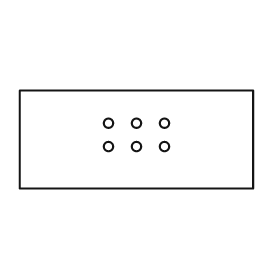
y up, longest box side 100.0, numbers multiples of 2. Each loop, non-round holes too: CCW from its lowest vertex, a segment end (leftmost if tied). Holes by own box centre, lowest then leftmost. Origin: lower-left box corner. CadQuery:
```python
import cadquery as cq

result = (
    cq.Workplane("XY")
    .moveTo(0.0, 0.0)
    .lineTo(100.0, 0.0)
    .lineTo(100.0, 42.0)
    .lineTo(0.0, 42.0)
    .close()
    .moveTo(38.0, 18.0)
    .circle(2.0)
    .moveTo(50.0, 18.0)
    .circle(2.0)
    .moveTo(62.0, 18.0)
    .circle(2.0)
    .moveTo(38.0, 28.0)
    .circle(2.0)
    .moveTo(50.0, 28.0)
    .circle(2.0)
    .moveTo(62.0, 28.0)
    .circle(2.0)
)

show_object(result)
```